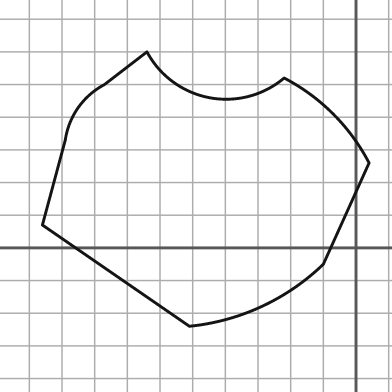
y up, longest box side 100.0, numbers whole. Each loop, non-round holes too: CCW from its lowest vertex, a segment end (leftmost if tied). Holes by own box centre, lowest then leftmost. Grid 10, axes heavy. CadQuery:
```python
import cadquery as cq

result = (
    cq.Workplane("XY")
    .moveTo(-51.0, -24.0)
    .threePointArc((-29.0, -18.0), (-10.0, -5.0))
    .lineTo(4.0, 26.0)
    .threePointArc((-7.0, 41.0), (-22.0, 52.0))
    .threePointArc((-45.0, 46.0), (-64.0, 60.0))
    .lineTo(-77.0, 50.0)
    .threePointArc((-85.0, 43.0), (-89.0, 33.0))
    .lineTo(-96.0, 7.0)
    .close()
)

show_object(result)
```